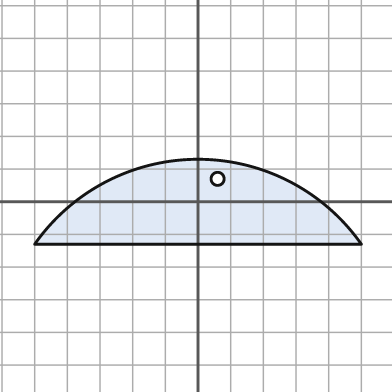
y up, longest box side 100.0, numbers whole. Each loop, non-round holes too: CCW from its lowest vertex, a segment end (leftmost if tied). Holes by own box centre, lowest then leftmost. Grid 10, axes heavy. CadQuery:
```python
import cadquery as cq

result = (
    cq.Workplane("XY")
    .moveTo(-50.0, -13.0)
    .lineTo(50.0, -13.0)
    .threePointArc((0.0, 13.0), (-50.0, -13.0))
    .close()
    .moveTo(6.0, 7.0)
    .circle(2.0)
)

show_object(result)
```